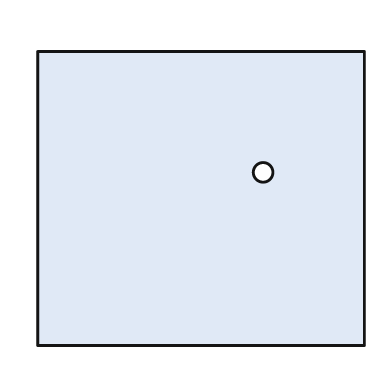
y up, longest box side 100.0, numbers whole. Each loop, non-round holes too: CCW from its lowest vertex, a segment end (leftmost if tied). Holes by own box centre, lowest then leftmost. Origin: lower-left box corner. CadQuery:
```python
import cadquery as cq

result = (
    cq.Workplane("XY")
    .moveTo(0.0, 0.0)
    .lineTo(100.0, 0.0)
    .lineTo(100.0, 90.0)
    .lineTo(0.0, 90.0)
    .close()
    .moveTo(69.0, 53.0)
    .circle(3.0)
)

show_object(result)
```